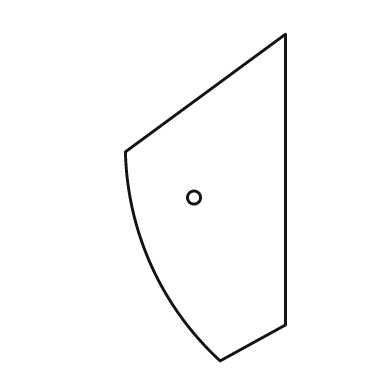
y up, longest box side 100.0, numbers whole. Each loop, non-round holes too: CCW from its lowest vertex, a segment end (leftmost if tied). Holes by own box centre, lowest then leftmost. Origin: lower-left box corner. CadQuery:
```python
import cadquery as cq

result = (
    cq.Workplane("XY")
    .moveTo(29.0, 0.0)
    .lineTo(49.0, 11.0)
    .lineTo(49.0, 100.0)
    .lineTo(0.0, 64.0)
    .threePointArc((8.0, 29.0), (29.0, 0.0))
    .close()
    .moveTo(21.0, 50.0)
    .circle(2.0)
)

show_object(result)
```